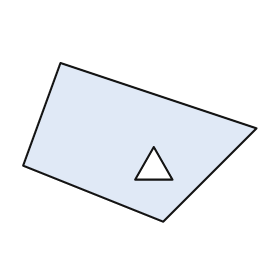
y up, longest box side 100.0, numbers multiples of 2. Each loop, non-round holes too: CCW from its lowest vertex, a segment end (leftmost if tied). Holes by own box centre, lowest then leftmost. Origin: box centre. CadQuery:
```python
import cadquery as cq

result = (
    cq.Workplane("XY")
    .moveTo(10.0, -34.0)
    .lineTo(50.0, 6.0)
    .lineTo(-34.0, 34.0)
    .lineTo(-50.0, -10.0)
    .close()
    .moveTo(-2.0, -16.0)
    .lineTo(14.0, -16.0)
    .lineTo(6.0, -2.0)
    .close()
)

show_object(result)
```